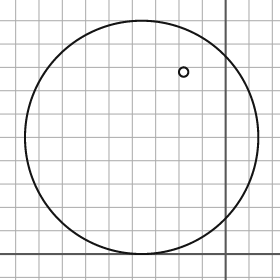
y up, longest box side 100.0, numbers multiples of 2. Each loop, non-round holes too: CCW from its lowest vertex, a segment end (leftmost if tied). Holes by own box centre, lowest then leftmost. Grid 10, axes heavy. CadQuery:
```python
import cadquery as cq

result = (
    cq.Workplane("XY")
    .moveTo(-36.0, 50.0)
    .circle(50.0)
    .moveTo(-18.0, 78.0)
    .circle(2.0)
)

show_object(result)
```